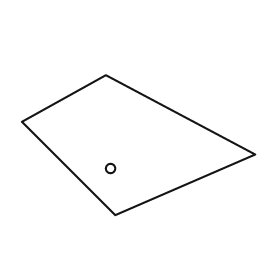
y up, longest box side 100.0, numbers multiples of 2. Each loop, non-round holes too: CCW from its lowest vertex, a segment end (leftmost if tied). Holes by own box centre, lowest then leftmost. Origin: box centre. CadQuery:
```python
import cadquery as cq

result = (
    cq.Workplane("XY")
    .moveTo(-10.0, -30.0)
    .lineTo(50.0, -4.0)
    .lineTo(-14.0, 30.0)
    .lineTo(-50.0, 10.0)
    .close()
    .moveTo(-12.0, -10.0)
    .circle(2.0)
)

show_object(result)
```